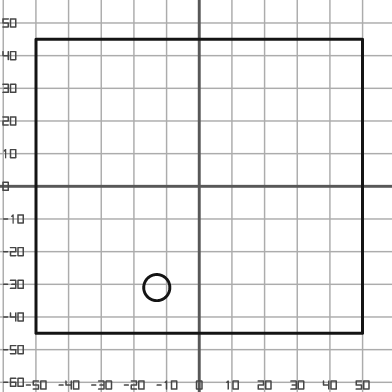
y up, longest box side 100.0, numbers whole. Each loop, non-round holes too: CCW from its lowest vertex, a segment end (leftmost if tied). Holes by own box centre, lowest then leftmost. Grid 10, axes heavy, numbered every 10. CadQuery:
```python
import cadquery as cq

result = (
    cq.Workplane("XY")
    .moveTo(-50.0, -45.0)
    .lineTo(50.0, -45.0)
    .lineTo(50.0, 45.0)
    .lineTo(-50.0, 45.0)
    .close()
    .moveTo(-13.0, -31.0)
    .circle(4.0)
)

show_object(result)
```